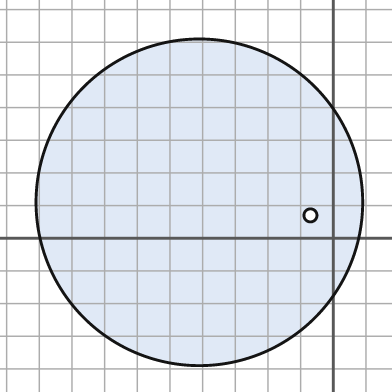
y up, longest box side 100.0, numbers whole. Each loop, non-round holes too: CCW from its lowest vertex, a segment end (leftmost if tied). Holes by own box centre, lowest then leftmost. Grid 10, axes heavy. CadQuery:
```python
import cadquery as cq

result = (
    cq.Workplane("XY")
    .moveTo(-41.0, 11.0)
    .circle(50.0)
    .moveTo(-7.0, 7.0)
    .circle(2.0)
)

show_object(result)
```